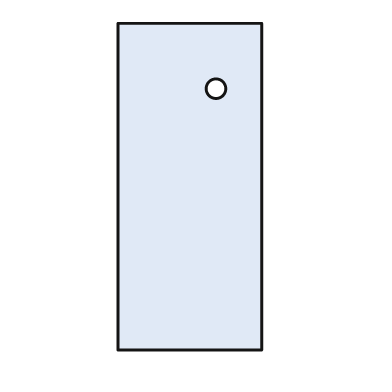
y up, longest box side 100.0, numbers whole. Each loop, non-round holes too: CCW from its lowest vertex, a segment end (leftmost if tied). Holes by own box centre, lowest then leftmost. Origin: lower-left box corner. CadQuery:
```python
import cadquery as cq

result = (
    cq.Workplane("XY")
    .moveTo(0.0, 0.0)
    .lineTo(44.0, 0.0)
    .lineTo(44.0, 100.0)
    .lineTo(0.0, 100.0)
    .close()
    .moveTo(30.0, 80.0)
    .circle(3.0)
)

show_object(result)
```